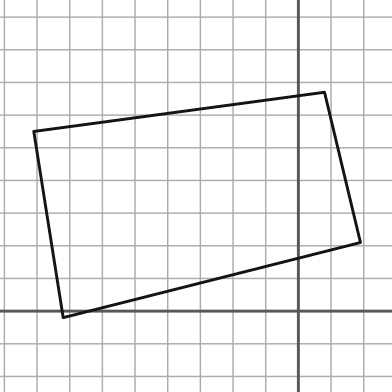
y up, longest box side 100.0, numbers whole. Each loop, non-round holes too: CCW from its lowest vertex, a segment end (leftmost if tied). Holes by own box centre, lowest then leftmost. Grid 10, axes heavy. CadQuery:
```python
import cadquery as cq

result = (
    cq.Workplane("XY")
    .moveTo(-72.0, -2.0)
    .lineTo(19.0, 21.0)
    .lineTo(8.0, 67.0)
    .lineTo(-81.0, 55.0)
    .close()
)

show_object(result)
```